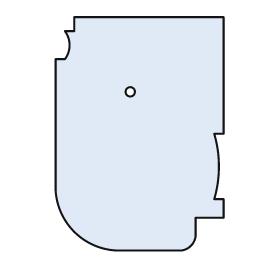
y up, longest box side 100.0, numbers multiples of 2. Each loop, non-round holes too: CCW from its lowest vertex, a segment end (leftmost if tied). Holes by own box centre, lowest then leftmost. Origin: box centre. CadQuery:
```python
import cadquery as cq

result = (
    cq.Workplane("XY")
    .moveTo(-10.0, -50.0)
    .lineTo(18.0, -50.0)
    .threePointArc((22.0, -48.0), (24.0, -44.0))
    .lineTo(24.0, -36.0)
    .lineTo(36.0, -36.0)
    .lineTo(36.0, -28.0)
    .lineTo(32.0, -28.0)
    .threePointArc((34.0, -14.0), (32.0, 0.0))
    .lineTo(36.0, 0.0)
    .lineTo(36.0, 50.0)
    .lineTo(-28.0, 50.0)
    .lineTo(-28.0, 44.0)
    .lineTo(-32.0, 44.0)
    .threePointArc((-30.0, 38.0), (-32.0, 32.0))
    .lineTo(-36.0, 32.0)
    .lineTo(-36.0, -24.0)
    .threePointArc((-28.0, -42.0), (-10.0, -50.0))
    .close()
    .moveTo(-4.0, 18.0)
    .circle(2.0)
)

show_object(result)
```